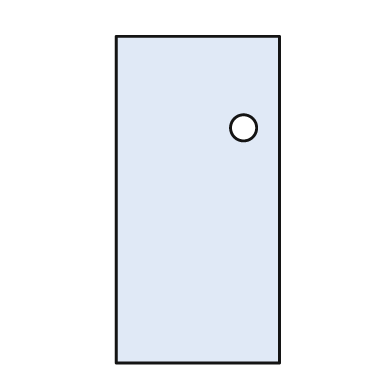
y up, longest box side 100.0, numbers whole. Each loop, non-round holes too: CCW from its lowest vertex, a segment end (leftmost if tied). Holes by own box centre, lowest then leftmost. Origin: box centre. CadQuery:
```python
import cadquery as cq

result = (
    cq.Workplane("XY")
    .moveTo(-25.0, -50.0)
    .lineTo(25.0, -50.0)
    .lineTo(25.0, 50.0)
    .lineTo(-25.0, 50.0)
    .close()
    .moveTo(14.0, 22.0)
    .circle(4.0)
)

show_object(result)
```